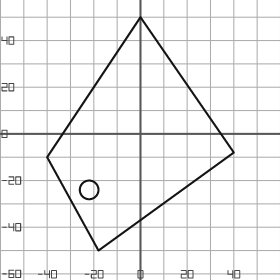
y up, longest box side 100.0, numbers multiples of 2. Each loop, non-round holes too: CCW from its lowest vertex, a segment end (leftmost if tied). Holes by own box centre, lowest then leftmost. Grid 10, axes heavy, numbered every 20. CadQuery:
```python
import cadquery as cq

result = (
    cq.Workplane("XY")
    .moveTo(-18.0, -50.0)
    .lineTo(40.0, -8.0)
    .lineTo(0.0, 50.0)
    .lineTo(-40.0, -10.0)
    .close()
    .moveTo(-22.0, -24.0)
    .circle(4.0)
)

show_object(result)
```